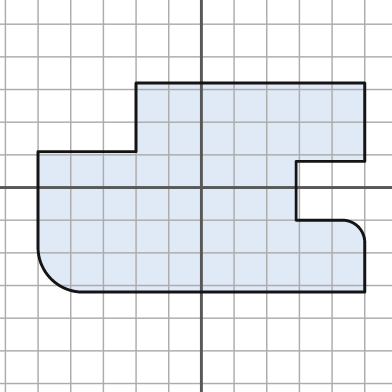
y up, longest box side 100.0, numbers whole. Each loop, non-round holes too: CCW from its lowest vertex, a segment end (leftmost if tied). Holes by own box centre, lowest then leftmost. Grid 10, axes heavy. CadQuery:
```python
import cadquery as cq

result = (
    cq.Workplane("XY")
    .moveTo(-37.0, -32.0)
    .lineTo(50.0, -32.0)
    .lineTo(50.0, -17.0)
    .threePointArc((48.0, -12.0), (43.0, -10.0))
    .lineTo(29.0, -10.0)
    .lineTo(29.0, 8.0)
    .lineTo(50.0, 8.0)
    .lineTo(50.0, 32.0)
    .lineTo(-20.0, 32.0)
    .lineTo(-20.0, 11.0)
    .lineTo(-50.0, 11.0)
    .lineTo(-50.0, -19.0)
    .threePointArc((-46.0, -28.0), (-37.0, -32.0))
    .close()
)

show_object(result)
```